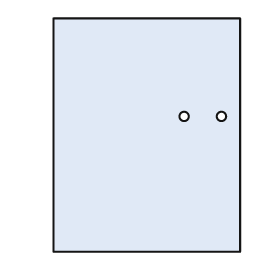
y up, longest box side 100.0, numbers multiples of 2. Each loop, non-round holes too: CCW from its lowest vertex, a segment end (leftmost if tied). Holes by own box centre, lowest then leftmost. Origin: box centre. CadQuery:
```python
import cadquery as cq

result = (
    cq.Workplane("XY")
    .moveTo(-40.0, -50.0)
    .lineTo(40.0, -50.0)
    .lineTo(40.0, 50.0)
    .lineTo(-40.0, 50.0)
    .close()
    .moveTo(16.0, 8.0)
    .circle(2.0)
    .moveTo(32.0, 8.0)
    .circle(2.0)
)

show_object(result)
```